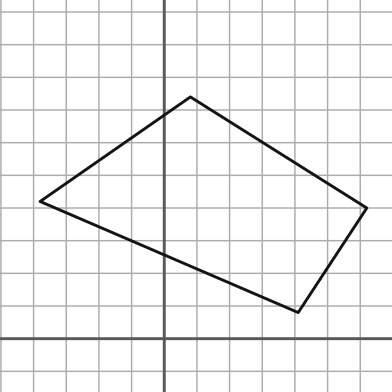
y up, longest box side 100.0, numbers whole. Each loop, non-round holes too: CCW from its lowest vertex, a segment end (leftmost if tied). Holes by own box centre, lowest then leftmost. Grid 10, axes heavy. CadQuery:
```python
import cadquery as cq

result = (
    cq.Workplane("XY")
    .moveTo(41.0, 8.0)
    .lineTo(62.0, 40.0)
    .lineTo(8.0, 74.0)
    .lineTo(-38.0, 42.0)
    .close()
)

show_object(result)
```